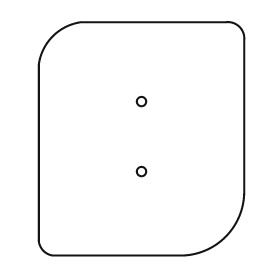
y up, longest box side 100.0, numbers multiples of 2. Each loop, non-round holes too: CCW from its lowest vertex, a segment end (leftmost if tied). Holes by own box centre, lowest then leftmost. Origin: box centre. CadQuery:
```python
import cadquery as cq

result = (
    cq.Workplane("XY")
    .moveTo(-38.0, -50.0)
    .lineTo(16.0, -50.0)
    .threePointArc((36.0, -42.0), (44.0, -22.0))
    .lineTo(44.0, 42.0)
    .threePointArc((42.0, 48.0), (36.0, 50.0))
    .lineTo(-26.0, 50.0)
    .threePointArc((-38.0, 44.0), (-44.0, 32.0))
    .lineTo(-44.0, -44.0)
    .threePointArc((-42.0, -48.0), (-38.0, -50.0))
    .close()
    .moveTo(0.0, -14.0)
    .circle(2.0)
    .moveTo(0.0, 16.0)
    .circle(2.0)
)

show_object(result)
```